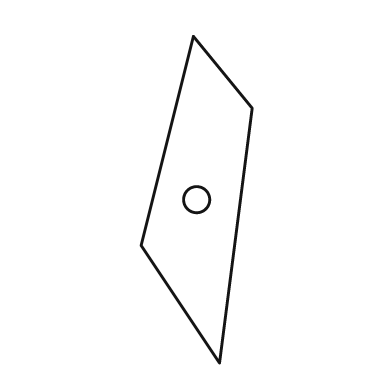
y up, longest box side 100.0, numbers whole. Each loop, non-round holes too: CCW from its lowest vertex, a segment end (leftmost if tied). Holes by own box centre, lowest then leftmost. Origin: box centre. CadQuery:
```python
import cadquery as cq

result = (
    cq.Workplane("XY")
    .moveTo(7.0, -50.0)
    .lineTo(17.0, 28.0)
    .lineTo(-1.0, 50.0)
    .lineTo(-17.0, -14.0)
    .close()
    .moveTo(0.0, 0.0)
    .circle(4.0)
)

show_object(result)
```